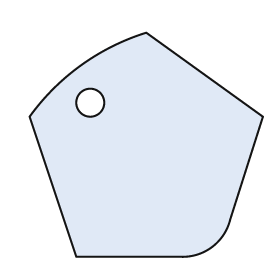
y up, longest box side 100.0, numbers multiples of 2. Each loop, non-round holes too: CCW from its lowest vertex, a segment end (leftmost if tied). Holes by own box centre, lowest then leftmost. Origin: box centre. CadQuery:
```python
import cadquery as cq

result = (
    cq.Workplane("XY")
    .moveTo(-30.0, -48.0)
    .lineTo(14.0, -48.0)
    .threePointArc((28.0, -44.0), (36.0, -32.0))
    .lineTo(50.0, 12.0)
    .lineTo(0.0, 48.0)
    .threePointArc((-28.0, 34.0), (-50.0, 12.0))
    .close()
    .moveTo(-24.0, 18.0)
    .circle(6.0)
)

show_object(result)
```